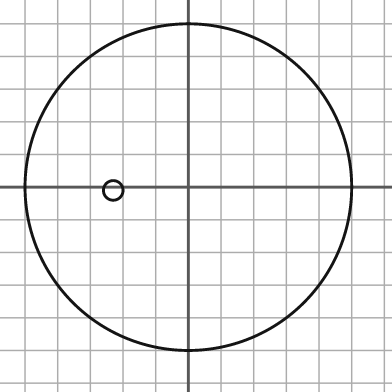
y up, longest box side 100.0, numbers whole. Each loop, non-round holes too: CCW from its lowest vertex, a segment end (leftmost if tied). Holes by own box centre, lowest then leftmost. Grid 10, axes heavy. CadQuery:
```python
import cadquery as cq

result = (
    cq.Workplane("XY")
    .moveTo(0.0, 0.0)
    .circle(50.0)
    .moveTo(-23.0, -1.0)
    .circle(3.0)
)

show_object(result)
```